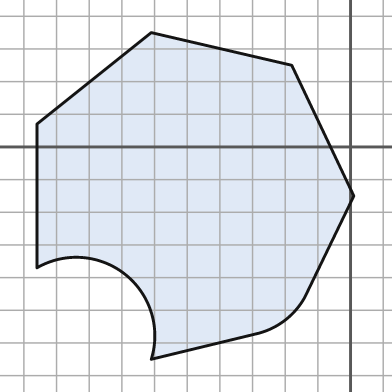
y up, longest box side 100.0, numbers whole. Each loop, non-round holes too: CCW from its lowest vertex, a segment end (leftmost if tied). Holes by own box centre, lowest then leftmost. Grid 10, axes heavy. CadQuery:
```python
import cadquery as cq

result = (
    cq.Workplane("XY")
    .moveTo(-61.0, -65.0)
    .lineTo(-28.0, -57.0)
    .threePointArc((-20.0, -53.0), (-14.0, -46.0))
    .lineTo(1.0, -15.0)
    .lineTo(-18.0, 25.0)
    .lineTo(-61.0, 35.0)
    .lineTo(-96.0, 7.0)
    .lineTo(-96.0, -37.0)
    .threePointArc((-69.0, -39.0), (-61.0, -65.0))
    .close()
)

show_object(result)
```